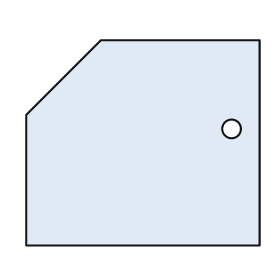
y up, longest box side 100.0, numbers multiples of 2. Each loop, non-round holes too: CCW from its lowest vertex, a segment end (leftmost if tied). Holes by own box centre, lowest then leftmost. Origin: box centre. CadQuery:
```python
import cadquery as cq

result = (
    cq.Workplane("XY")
    .moveTo(-50.0, -44.0)
    .lineTo(50.0, -44.0)
    .lineTo(50.0, 44.0)
    .lineTo(-18.0, 44.0)
    .lineTo(-50.0, 12.0)
    .close()
    .moveTo(38.0, 6.0)
    .circle(4.0)
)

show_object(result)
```